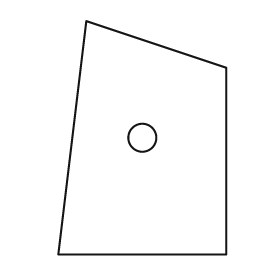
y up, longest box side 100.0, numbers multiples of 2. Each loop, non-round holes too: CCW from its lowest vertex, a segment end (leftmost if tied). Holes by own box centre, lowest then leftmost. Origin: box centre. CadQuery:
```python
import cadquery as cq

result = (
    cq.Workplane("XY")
    .moveTo(-36.0, -50.0)
    .lineTo(36.0, -50.0)
    .lineTo(36.0, 30.0)
    .lineTo(-24.0, 50.0)
    .close()
    .moveTo(0.0, 0.0)
    .circle(6.0)
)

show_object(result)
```